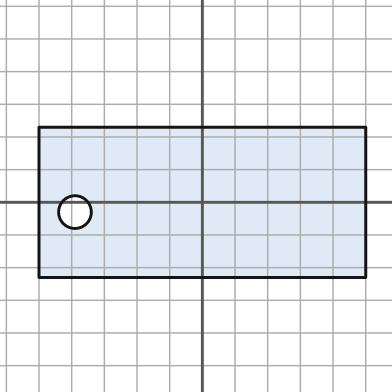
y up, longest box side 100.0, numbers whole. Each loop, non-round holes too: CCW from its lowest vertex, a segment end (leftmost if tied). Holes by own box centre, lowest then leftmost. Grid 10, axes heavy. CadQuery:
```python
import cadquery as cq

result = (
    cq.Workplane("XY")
    .moveTo(-50.0, -23.0)
    .lineTo(50.0, -23.0)
    .lineTo(50.0, 23.0)
    .lineTo(-50.0, 23.0)
    .close()
    .moveTo(-39.0, -3.0)
    .circle(5.0)
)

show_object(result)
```